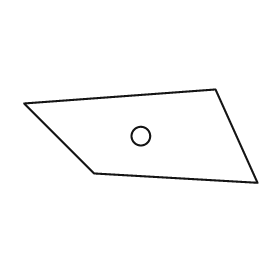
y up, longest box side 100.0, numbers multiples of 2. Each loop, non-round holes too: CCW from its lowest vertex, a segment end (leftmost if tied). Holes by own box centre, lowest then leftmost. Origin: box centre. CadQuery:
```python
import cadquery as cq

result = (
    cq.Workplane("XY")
    .moveTo(50.0, -20.0)
    .lineTo(32.0, 20.0)
    .lineTo(-50.0, 14.0)
    .lineTo(-20.0, -16.0)
    .close()
    .moveTo(0.0, 0.0)
    .circle(4.0)
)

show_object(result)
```